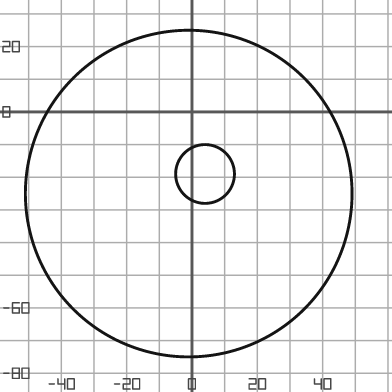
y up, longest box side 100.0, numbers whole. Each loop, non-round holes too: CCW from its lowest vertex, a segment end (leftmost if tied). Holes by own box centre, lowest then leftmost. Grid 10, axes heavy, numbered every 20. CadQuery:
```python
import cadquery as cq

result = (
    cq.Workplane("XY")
    .moveTo(-1.0, -25.0)
    .circle(50.0)
    .moveTo(4.0, -19.0)
    .circle(9.0)
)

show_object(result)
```